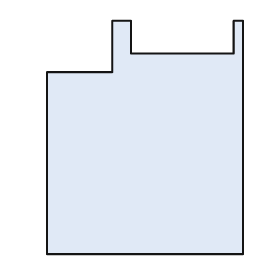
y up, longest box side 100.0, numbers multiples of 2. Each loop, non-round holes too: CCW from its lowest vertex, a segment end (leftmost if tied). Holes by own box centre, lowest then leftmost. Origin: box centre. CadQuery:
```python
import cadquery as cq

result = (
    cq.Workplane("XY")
    .moveTo(-42.0, -50.0)
    .lineTo(42.0, -50.0)
    .lineTo(42.0, 50.0)
    .lineTo(38.0, 50.0)
    .lineTo(38.0, 36.0)
    .lineTo(-6.0, 36.0)
    .lineTo(-6.0, 50.0)
    .lineTo(-14.0, 50.0)
    .lineTo(-14.0, 28.0)
    .lineTo(-42.0, 28.0)
    .close()
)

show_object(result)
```